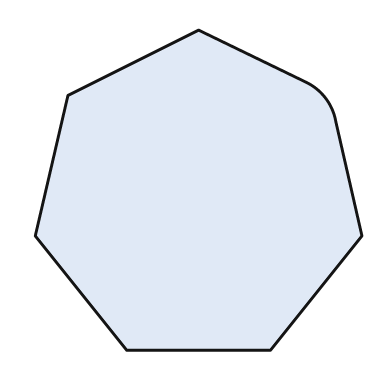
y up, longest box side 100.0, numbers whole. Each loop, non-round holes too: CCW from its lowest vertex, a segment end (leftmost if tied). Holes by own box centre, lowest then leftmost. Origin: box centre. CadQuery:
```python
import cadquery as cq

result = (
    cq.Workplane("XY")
    .moveTo(-22.0, -49.0)
    .lineTo(22.0, -49.0)
    .lineTo(50.0, -14.0)
    .lineTo(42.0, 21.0)
    .threePointArc((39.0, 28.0), (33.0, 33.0))
    .lineTo(0.0, 49.0)
    .lineTo(-40.0, 29.0)
    .lineTo(-50.0, -14.0)
    .close()
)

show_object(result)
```